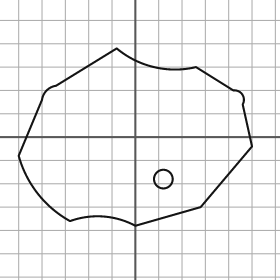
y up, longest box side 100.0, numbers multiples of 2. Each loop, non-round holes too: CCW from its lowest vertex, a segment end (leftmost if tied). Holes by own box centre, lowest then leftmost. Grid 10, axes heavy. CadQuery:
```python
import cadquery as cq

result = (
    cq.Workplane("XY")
    .moveTo(0.0, -38.0)
    .lineTo(28.0, -30.0)
    .lineTo(50.0, -4.0)
    .lineTo(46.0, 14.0)
    .threePointArc((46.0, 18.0), (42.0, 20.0))
    .lineTo(26.0, 30.0)
    .threePointArc((8.0, 30.0), (-8.0, 38.0))
    .lineTo(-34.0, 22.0)
    .threePointArc((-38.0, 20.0), (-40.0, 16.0))
    .lineTo(-50.0, -8.0)
    .threePointArc((-42.0, -24.0), (-28.0, -36.0))
    .threePointArc((-14.0, -34.0), (0.0, -38.0))
    .close()
    .moveTo(12.0, -18.0)
    .circle(4.0)
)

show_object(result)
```